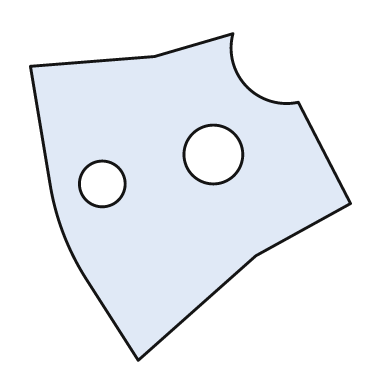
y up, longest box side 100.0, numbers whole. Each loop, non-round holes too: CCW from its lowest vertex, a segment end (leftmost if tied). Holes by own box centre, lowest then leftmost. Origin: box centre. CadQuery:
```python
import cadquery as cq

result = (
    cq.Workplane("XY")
    .moveTo(-16.0, -50.0)
    .lineTo(20.0, -18.0)
    .lineTo(49.0, -2.0)
    .lineTo(33.0, 29.0)
    .threePointArc((17.0, 34.0), (13.0, 50.0))
    .lineTo(-11.0, 43.0)
    .lineTo(-49.0, 40.0)
    .lineTo(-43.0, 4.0)
    .threePointArc((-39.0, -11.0), (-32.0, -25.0))
    .close()
    .moveTo(-27.0, 4.0)
    .circle(7.0)
    .moveTo(7.0, 13.0)
    .circle(9.0)
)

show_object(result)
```